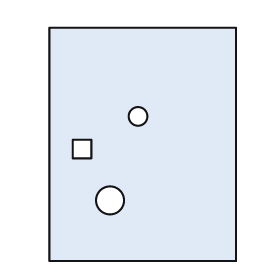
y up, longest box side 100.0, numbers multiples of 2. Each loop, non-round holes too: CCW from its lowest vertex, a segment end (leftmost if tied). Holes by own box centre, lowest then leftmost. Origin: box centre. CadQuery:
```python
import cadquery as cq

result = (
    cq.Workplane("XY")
    .moveTo(-40.0, -50.0)
    .lineTo(40.0, -50.0)
    .lineTo(40.0, 50.0)
    .lineTo(-40.0, 50.0)
    .close()
    .moveTo(-14.0, -24.0)
    .circle(6.0)
    .moveTo(-30.0, -6.0)
    .lineTo(-22.0, -6.0)
    .lineTo(-22.0, 2.0)
    .lineTo(-30.0, 2.0)
    .close()
    .moveTo(-2.0, 12.0)
    .circle(4.0)
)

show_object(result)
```